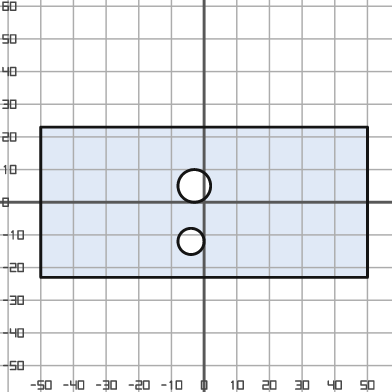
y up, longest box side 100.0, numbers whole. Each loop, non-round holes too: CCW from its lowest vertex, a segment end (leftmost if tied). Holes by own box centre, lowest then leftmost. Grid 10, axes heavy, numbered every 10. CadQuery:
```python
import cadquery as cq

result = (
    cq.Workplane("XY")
    .moveTo(-50.0, -23.0)
    .lineTo(50.0, -23.0)
    .lineTo(50.0, 23.0)
    .lineTo(-50.0, 23.0)
    .close()
    .moveTo(-4.0, -12.0)
    .circle(4.0)
    .moveTo(-3.0, 5.0)
    .circle(5.0)
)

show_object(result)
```